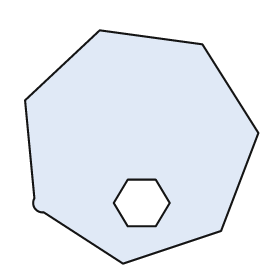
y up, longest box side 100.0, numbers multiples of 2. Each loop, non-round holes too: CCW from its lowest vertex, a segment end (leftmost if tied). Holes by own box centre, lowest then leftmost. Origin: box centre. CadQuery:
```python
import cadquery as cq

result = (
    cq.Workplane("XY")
    .moveTo(-8.0, -50.0)
    .lineTo(34.0, -36.0)
    .lineTo(50.0, 6.0)
    .lineTo(26.0, 44.0)
    .lineTo(-18.0, 50.0)
    .lineTo(-50.0, 20.0)
    .lineTo(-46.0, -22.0)
    .threePointArc((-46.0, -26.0), (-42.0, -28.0))
    .close()
    .moveTo(-6.0, -34.0)
    .lineTo(6.0, -34.0)
    .lineTo(12.0, -24.0)
    .lineTo(6.0, -14.0)
    .lineTo(-6.0, -14.0)
    .lineTo(-12.0, -24.0)
    .close()
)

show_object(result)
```